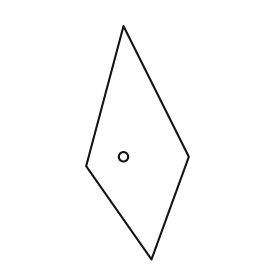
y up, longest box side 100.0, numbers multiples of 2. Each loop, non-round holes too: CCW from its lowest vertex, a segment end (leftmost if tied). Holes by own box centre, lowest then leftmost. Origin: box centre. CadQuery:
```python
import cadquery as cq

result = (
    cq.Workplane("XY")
    .moveTo(6.0, -50.0)
    .lineTo(22.0, -6.0)
    .lineTo(-6.0, 50.0)
    .lineTo(-22.0, -10.0)
    .close()
    .moveTo(-6.0, -6.0)
    .circle(2.0)
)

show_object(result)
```